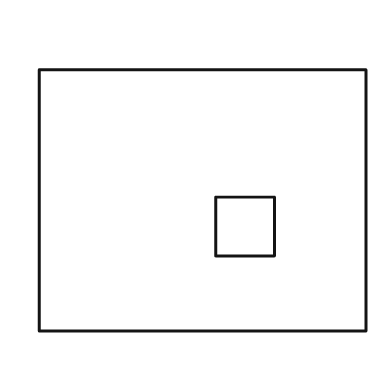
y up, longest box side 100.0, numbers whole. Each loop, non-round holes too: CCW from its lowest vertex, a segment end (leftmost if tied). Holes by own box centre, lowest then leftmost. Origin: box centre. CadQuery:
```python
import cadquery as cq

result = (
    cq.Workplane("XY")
    .moveTo(-50.0, -40.0)
    .lineTo(50.0, -40.0)
    .lineTo(50.0, 40.0)
    .lineTo(-50.0, 40.0)
    .close()
    .moveTo(4.0, -17.0)
    .lineTo(22.0, -17.0)
    .lineTo(22.0, 1.0)
    .lineTo(4.0, 1.0)
    .close()
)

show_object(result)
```